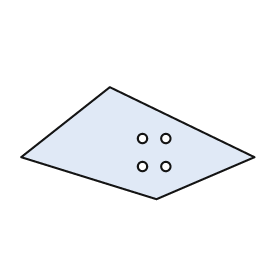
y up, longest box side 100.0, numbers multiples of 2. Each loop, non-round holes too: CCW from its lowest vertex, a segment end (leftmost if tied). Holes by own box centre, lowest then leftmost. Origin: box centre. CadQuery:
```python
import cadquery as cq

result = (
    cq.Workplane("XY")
    .moveTo(8.0, -24.0)
    .lineTo(50.0, -6.0)
    .lineTo(-12.0, 24.0)
    .lineTo(-50.0, -6.0)
    .close()
    .moveTo(2.0, -10.0)
    .circle(2.0)
    .moveTo(12.0, -10.0)
    .circle(2.0)
    .moveTo(2.0, 2.0)
    .circle(2.0)
    .moveTo(12.0, 2.0)
    .circle(2.0)
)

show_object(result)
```